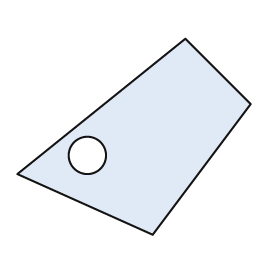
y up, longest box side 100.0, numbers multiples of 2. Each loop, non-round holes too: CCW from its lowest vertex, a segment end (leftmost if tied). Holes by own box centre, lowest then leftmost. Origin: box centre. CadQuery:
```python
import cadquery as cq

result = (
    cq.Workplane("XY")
    .moveTo(8.0, -42.0)
    .lineTo(50.0, 14.0)
    .lineTo(22.0, 42.0)
    .lineTo(-50.0, -16.0)
    .close()
    .moveTo(-20.0, -8.0)
    .circle(8.0)
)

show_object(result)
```